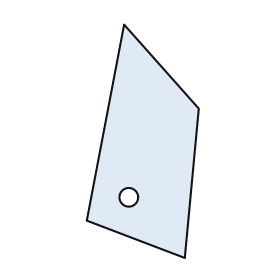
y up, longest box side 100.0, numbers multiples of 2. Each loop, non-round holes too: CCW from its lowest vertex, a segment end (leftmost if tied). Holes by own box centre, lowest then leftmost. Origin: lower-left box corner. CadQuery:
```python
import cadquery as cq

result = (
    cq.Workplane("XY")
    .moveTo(42.0, 0.0)
    .lineTo(48.0, 64.0)
    .lineTo(16.0, 100.0)
    .lineTo(0.0, 16.0)
    .close()
    .moveTo(18.0, 26.0)
    .circle(4.0)
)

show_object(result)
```